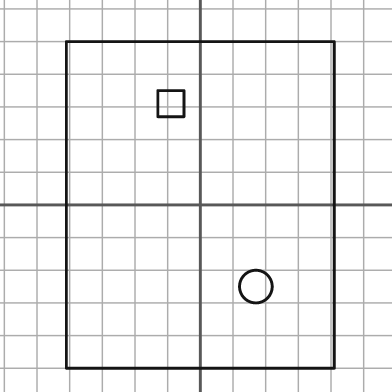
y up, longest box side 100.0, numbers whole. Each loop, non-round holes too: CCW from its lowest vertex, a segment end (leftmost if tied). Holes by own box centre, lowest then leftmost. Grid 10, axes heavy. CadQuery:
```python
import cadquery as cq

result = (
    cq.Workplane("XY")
    .moveTo(-41.0, -50.0)
    .lineTo(41.0, -50.0)
    .lineTo(41.0, 50.0)
    .lineTo(-41.0, 50.0)
    .close()
    .moveTo(17.0, -25.0)
    .circle(5.0)
    .moveTo(-13.0, 27.0)
    .lineTo(-5.0, 27.0)
    .lineTo(-5.0, 35.0)
    .lineTo(-13.0, 35.0)
    .close()
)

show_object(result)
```